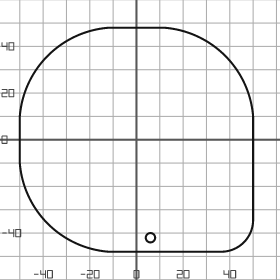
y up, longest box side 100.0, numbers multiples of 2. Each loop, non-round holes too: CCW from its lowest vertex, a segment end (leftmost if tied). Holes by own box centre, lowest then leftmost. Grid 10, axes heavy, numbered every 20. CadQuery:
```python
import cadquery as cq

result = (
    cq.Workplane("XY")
    .moveTo(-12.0, -48.0)
    .lineTo(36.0, -48.0)
    .threePointArc((46.0, -44.0), (50.0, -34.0))
    .lineTo(50.0, 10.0)
    .threePointArc((38.0, 36.0), (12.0, 48.0))
    .lineTo(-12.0, 48.0)
    .threePointArc((-38.0, 36.0), (-50.0, 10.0))
    .lineTo(-50.0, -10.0)
    .threePointArc((-38.0, -36.0), (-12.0, -48.0))
    .close()
    .moveTo(6.0, -42.0)
    .circle(2.0)
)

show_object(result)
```